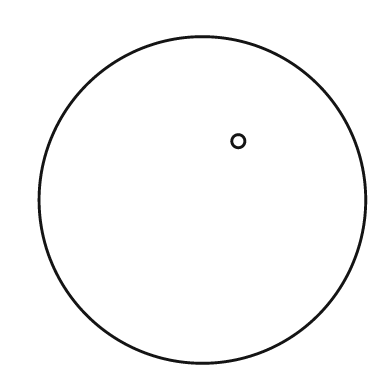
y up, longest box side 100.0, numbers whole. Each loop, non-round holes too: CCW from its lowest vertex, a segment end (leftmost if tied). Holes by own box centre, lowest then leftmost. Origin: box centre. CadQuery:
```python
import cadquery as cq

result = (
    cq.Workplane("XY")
    .moveTo(0.0, 0.0)
    .circle(50.0)
    .moveTo(11.0, 18.0)
    .circle(2.0)
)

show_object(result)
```